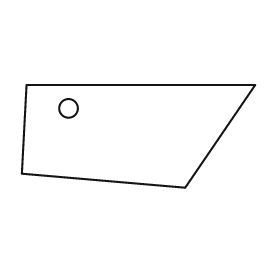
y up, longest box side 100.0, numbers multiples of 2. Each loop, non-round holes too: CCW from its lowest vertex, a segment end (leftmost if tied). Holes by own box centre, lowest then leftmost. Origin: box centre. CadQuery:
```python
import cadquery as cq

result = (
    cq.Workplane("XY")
    .moveTo(20.0, -22.0)
    .lineTo(50.0, 22.0)
    .lineTo(-48.0, 22.0)
    .lineTo(-50.0, -16.0)
    .close()
    .moveTo(-30.0, 12.0)
    .circle(4.0)
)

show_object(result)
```